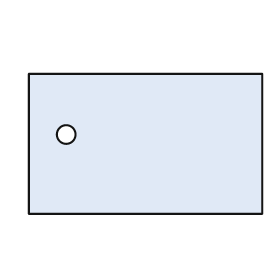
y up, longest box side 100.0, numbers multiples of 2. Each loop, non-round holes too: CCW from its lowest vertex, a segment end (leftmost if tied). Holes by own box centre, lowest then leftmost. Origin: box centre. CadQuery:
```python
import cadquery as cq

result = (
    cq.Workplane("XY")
    .moveTo(-50.0, -30.0)
    .lineTo(50.0, -30.0)
    .lineTo(50.0, 30.0)
    .lineTo(-50.0, 30.0)
    .close()
    .moveTo(-34.0, 4.0)
    .circle(4.0)
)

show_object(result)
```